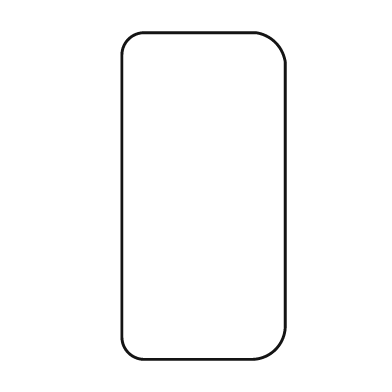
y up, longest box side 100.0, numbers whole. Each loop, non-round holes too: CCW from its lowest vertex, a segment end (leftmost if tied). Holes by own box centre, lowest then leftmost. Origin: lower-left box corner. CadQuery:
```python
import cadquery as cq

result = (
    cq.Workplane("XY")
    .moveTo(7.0, 0.0)
    .lineTo(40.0, 0.0)
    .threePointArc((47.0, 3.0), (50.0, 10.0))
    .lineTo(50.0, 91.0)
    .threePointArc((47.0, 97.0), (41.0, 100.0))
    .lineTo(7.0, 100.0)
    .threePointArc((2.0, 98.0), (0.0, 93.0))
    .lineTo(0.0, 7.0)
    .threePointArc((2.0, 2.0), (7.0, 0.0))
    .close()
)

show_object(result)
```